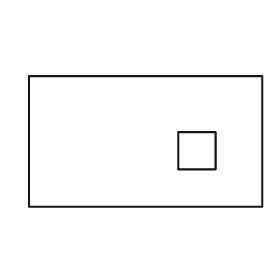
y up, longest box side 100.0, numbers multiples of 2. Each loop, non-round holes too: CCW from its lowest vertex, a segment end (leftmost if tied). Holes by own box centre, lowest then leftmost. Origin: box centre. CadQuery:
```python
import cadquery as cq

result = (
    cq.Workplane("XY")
    .moveTo(-50.0, -28.0)
    .lineTo(50.0, -28.0)
    .lineTo(50.0, 28.0)
    .lineTo(-50.0, 28.0)
    .close()
    .moveTo(14.0, -12.0)
    .lineTo(30.0, -12.0)
    .lineTo(30.0, 4.0)
    .lineTo(14.0, 4.0)
    .close()
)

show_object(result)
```